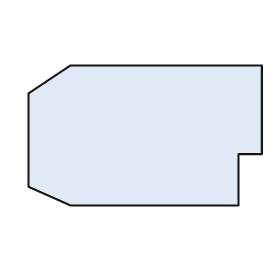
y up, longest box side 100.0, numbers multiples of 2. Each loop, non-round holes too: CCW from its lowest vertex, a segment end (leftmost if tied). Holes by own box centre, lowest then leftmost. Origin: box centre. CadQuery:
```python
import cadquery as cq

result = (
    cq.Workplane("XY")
    .moveTo(-32.0, -30.0)
    .lineTo(40.0, -30.0)
    .lineTo(40.0, -8.0)
    .lineTo(50.0, -8.0)
    .lineTo(50.0, 30.0)
    .lineTo(-32.0, 30.0)
    .lineTo(-50.0, 18.0)
    .lineTo(-50.0, -22.0)
    .close()
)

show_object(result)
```